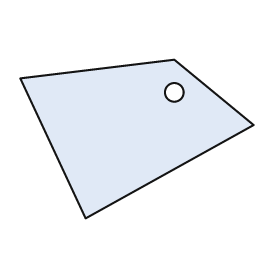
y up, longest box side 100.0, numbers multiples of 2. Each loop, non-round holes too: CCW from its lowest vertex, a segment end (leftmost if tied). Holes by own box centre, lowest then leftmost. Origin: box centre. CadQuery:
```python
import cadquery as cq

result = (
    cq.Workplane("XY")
    .moveTo(-22.0, -34.0)
    .lineTo(50.0, 6.0)
    .lineTo(16.0, 34.0)
    .lineTo(-50.0, 26.0)
    .close()
    .moveTo(16.0, 20.0)
    .circle(4.0)
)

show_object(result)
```